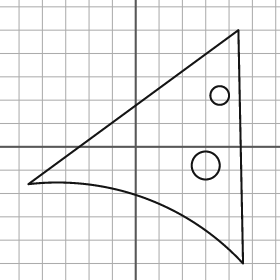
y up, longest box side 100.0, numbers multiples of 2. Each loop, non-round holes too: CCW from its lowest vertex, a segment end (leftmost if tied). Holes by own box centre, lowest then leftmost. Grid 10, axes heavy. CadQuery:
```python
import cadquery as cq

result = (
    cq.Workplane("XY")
    .moveTo(46.0, -50.0)
    .lineTo(44.0, 50.0)
    .lineTo(-46.0, -16.0)
    .threePointArc((4.0, -22.0), (46.0, -50.0))
    .close()
    .moveTo(30.0, -8.0)
    .circle(6.0)
    .moveTo(36.0, 22.0)
    .circle(4.0)
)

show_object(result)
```